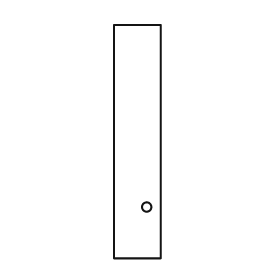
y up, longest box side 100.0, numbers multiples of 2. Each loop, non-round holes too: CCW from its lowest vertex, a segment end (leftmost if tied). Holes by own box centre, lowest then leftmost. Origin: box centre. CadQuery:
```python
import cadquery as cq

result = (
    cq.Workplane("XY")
    .moveTo(-10.0, -50.0)
    .lineTo(10.0, -50.0)
    .lineTo(10.0, 50.0)
    .lineTo(-10.0, 50.0)
    .close()
    .moveTo(4.0, -28.0)
    .circle(2.0)
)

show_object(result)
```